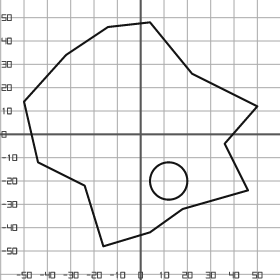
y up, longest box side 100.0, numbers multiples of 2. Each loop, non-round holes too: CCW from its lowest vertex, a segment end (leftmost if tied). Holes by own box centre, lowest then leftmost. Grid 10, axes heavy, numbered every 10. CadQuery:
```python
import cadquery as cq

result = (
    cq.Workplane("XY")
    .moveTo(-16.0, -48.0)
    .lineTo(4.0, -42.0)
    .lineTo(18.0, -32.0)
    .lineTo(46.0, -24.0)
    .lineTo(36.0, -4.0)
    .lineTo(50.0, 12.0)
    .lineTo(22.0, 26.0)
    .lineTo(4.0, 48.0)
    .lineTo(-14.0, 46.0)
    .lineTo(-32.0, 34.0)
    .lineTo(-50.0, 14.0)
    .lineTo(-44.0, -12.0)
    .lineTo(-24.0, -22.0)
    .close()
    .moveTo(12.0, -20.0)
    .circle(8.0)
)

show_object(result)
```